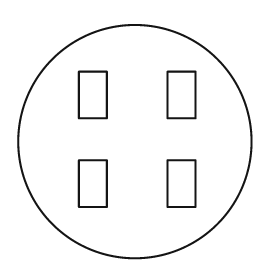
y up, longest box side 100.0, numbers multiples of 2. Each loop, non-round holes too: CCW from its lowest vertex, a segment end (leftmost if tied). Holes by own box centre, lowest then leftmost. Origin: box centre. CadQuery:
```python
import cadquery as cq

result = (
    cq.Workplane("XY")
    .moveTo(0.0, 0.0)
    .circle(50.0)
    .moveTo(-24.0, -28.0)
    .lineTo(-12.0, -28.0)
    .lineTo(-12.0, -8.0)
    .lineTo(-24.0, -8.0)
    .close()
    .moveTo(14.0, -28.0)
    .lineTo(26.0, -28.0)
    .lineTo(26.0, -8.0)
    .lineTo(14.0, -8.0)
    .close()
    .moveTo(-24.0, 10.0)
    .lineTo(-12.0, 10.0)
    .lineTo(-12.0, 30.0)
    .lineTo(-24.0, 30.0)
    .close()
    .moveTo(14.0, 10.0)
    .lineTo(26.0, 10.0)
    .lineTo(26.0, 30.0)
    .lineTo(14.0, 30.0)
    .close()
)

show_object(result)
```